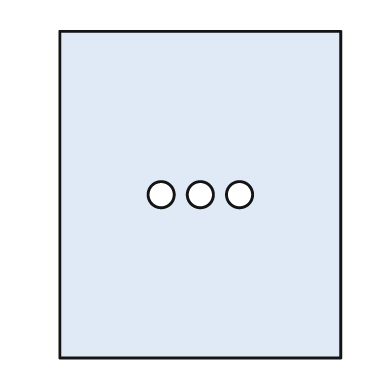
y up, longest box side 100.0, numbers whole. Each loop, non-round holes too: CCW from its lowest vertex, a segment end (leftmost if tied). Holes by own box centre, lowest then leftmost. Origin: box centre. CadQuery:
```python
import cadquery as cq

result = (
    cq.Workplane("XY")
    .moveTo(-43.0, -50.0)
    .lineTo(43.0, -50.0)
    .lineTo(43.0, 50.0)
    .lineTo(-43.0, 50.0)
    .close()
    .moveTo(-12.0, 0.0)
    .circle(4.0)
    .moveTo(0.0, 0.0)
    .circle(4.0)
    .moveTo(12.0, 0.0)
    .circle(4.0)
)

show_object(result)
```